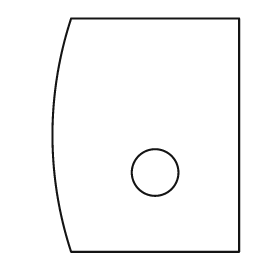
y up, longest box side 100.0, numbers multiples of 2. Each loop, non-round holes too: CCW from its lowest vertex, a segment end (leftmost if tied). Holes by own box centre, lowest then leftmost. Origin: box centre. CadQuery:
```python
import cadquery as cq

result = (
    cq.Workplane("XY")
    .moveTo(-32.0, -50.0)
    .lineTo(40.0, -50.0)
    .lineTo(40.0, 50.0)
    .lineTo(-32.0, 50.0)
    .threePointArc((-40.0, 0.0), (-32.0, -50.0))
    .close()
    .moveTo(4.0, -16.0)
    .circle(10.0)
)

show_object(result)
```